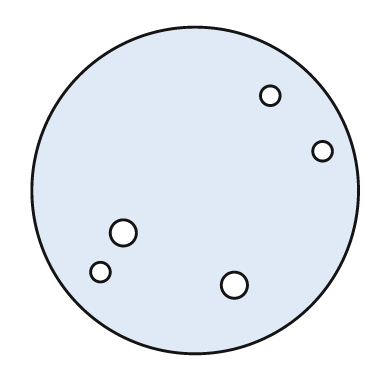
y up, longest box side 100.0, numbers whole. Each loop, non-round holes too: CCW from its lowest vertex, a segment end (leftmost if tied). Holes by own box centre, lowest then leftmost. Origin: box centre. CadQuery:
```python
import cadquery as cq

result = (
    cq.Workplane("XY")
    .moveTo(0.0, 0.0)
    .circle(50.0)
    .moveTo(12.0, -29.0)
    .circle(4.0)
    .moveTo(-29.0, -25.0)
    .circle(3.0)
    .moveTo(-22.0, -13.0)
    .circle(4.0)
    .moveTo(39.0, 12.0)
    .circle(3.0)
    .moveTo(23.0, 29.0)
    .circle(3.0)
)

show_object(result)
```